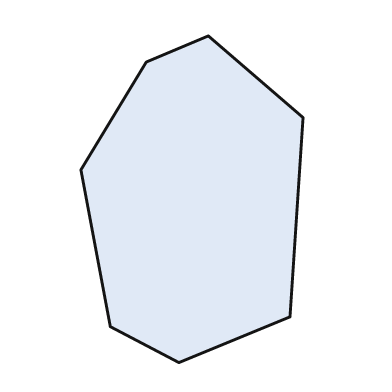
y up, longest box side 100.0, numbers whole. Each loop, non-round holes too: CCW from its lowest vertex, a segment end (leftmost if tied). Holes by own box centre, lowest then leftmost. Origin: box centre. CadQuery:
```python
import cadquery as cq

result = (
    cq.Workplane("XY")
    .moveTo(-4.0, -50.0)
    .lineTo(30.0, -36.0)
    .lineTo(34.0, 25.0)
    .lineTo(5.0, 50.0)
    .lineTo(-14.0, 42.0)
    .lineTo(-34.0, 9.0)
    .lineTo(-25.0, -39.0)
    .close()
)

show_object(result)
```